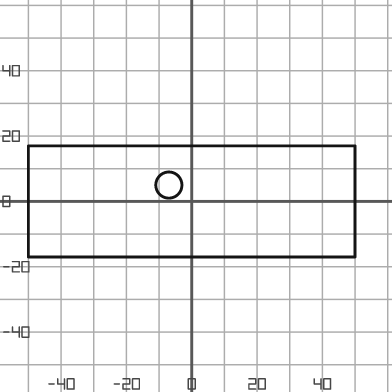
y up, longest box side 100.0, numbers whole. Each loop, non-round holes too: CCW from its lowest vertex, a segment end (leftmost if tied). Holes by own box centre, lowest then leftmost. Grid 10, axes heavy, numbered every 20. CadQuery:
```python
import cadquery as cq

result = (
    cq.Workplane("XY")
    .moveTo(-50.0, -17.0)
    .lineTo(50.0, -17.0)
    .lineTo(50.0, 17.0)
    .lineTo(-50.0, 17.0)
    .close()
    .moveTo(-7.0, 5.0)
    .circle(4.0)
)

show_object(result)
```